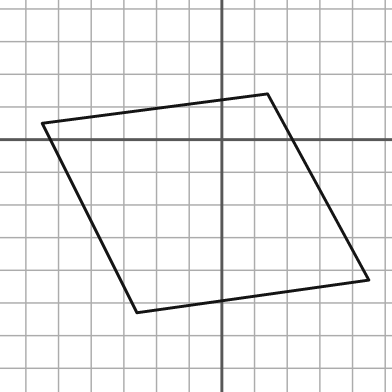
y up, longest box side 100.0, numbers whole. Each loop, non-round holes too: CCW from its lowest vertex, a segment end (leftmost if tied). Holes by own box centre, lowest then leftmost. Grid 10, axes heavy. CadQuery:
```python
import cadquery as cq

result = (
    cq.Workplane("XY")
    .moveTo(-26.0, -53.0)
    .lineTo(45.0, -43.0)
    .lineTo(14.0, 14.0)
    .lineTo(-55.0, 5.0)
    .close()
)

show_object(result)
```